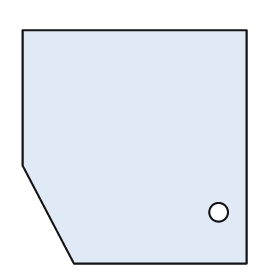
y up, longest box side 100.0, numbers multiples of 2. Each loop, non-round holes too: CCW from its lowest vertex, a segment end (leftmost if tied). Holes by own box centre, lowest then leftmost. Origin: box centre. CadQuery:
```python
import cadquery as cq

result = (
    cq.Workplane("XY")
    .moveTo(-26.0, -50.0)
    .lineTo(48.0, -50.0)
    .lineTo(48.0, 50.0)
    .lineTo(-48.0, 50.0)
    .lineTo(-48.0, -8.0)
    .close()
    .moveTo(36.0, -28.0)
    .circle(4.0)
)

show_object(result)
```